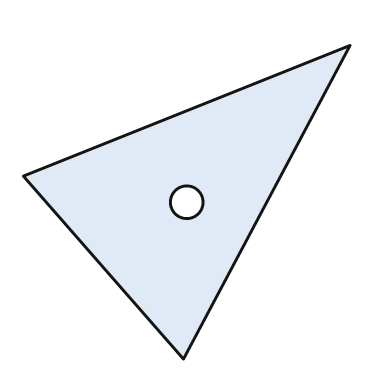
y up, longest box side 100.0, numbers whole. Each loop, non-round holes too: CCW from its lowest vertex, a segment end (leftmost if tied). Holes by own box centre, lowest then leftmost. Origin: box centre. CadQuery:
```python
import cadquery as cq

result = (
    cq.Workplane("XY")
    .moveTo(-1.0, -48.0)
    .lineTo(50.0, 48.0)
    .lineTo(-50.0, 8.0)
    .close()
    .moveTo(0.0, 0.0)
    .circle(5.0)
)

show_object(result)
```